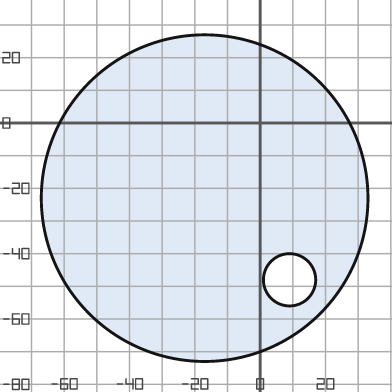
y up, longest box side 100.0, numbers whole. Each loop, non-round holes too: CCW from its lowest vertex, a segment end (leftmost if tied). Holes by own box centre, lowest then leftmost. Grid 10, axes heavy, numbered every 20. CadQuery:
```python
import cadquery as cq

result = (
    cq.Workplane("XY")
    .moveTo(-17.0, -23.0)
    .circle(50.0)
    .moveTo(9.0, -48.0)
    .circle(8.0)
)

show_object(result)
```